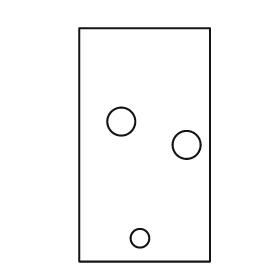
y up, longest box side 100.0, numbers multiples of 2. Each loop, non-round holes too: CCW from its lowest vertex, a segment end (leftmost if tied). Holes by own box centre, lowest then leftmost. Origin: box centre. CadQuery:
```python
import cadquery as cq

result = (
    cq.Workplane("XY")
    .moveTo(-28.0, -50.0)
    .lineTo(28.0, -50.0)
    .lineTo(28.0, 50.0)
    .lineTo(-28.0, 50.0)
    .close()
    .moveTo(-2.0, -40.0)
    .circle(4.0)
    .moveTo(18.0, 0.0)
    .circle(6.0)
    .moveTo(-10.0, 10.0)
    .circle(6.0)
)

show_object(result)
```